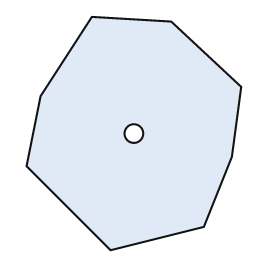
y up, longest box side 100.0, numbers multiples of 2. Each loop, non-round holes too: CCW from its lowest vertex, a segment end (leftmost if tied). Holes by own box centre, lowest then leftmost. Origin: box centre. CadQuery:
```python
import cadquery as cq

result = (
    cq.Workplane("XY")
    .moveTo(-10.0, -50.0)
    .lineTo(30.0, -40.0)
    .lineTo(42.0, -10.0)
    .lineTo(46.0, 20.0)
    .lineTo(16.0, 48.0)
    .lineTo(-18.0, 50.0)
    .lineTo(-40.0, 16.0)
    .lineTo(-46.0, -14.0)
    .close()
    .moveTo(0.0, 0.0)
    .circle(4.0)
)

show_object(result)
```